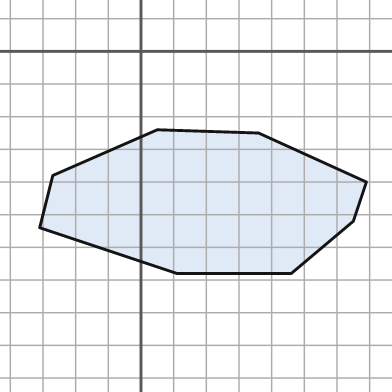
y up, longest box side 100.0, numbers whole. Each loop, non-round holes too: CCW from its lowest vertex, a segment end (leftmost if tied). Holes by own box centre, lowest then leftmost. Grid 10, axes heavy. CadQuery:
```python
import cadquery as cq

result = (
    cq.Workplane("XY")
    .moveTo(11.0, -68.0)
    .lineTo(46.0, -68.0)
    .lineTo(65.0, -52.0)
    .lineTo(69.0, -40.0)
    .lineTo(36.0, -25.0)
    .lineTo(5.0, -24.0)
    .lineTo(-27.0, -38.0)
    .lineTo(-31.0, -54.0)
    .close()
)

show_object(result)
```